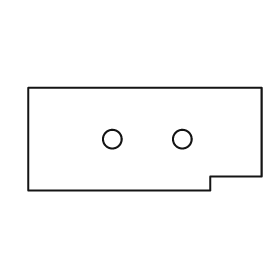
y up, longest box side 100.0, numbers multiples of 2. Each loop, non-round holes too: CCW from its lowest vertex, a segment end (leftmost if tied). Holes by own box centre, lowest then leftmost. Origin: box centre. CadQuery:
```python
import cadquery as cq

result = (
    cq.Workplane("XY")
    .moveTo(-50.0, -22.0)
    .lineTo(28.0, -22.0)
    .lineTo(28.0, -16.0)
    .lineTo(50.0, -16.0)
    .lineTo(50.0, 22.0)
    .lineTo(-50.0, 22.0)
    .close()
    .moveTo(-14.0, 0.0)
    .circle(4.0)
    .moveTo(16.0, 0.0)
    .circle(4.0)
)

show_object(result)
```